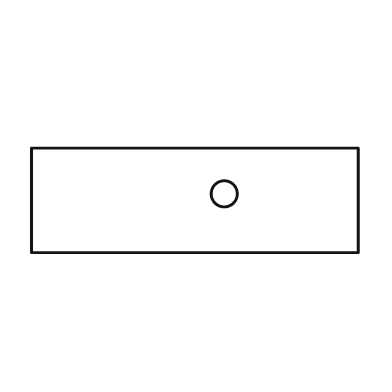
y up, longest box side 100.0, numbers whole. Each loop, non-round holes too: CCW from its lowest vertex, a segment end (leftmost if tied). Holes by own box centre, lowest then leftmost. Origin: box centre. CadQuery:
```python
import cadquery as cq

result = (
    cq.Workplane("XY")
    .moveTo(-50.0, -16.0)
    .lineTo(50.0, -16.0)
    .lineTo(50.0, 16.0)
    .lineTo(-50.0, 16.0)
    .close()
    .moveTo(9.0, 2.0)
    .circle(4.0)
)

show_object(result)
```